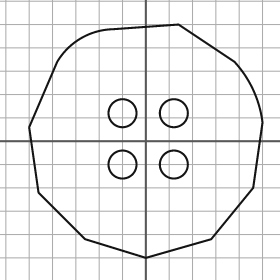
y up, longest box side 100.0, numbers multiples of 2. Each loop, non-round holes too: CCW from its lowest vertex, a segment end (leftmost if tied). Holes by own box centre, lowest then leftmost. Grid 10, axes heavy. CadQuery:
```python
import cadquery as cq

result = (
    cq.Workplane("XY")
    .moveTo(0.0, -50.0)
    .lineTo(28.0, -42.0)
    .lineTo(46.0, -20.0)
    .lineTo(50.0, 8.0)
    .threePointArc((46.0, 22.0), (38.0, 34.0))
    .lineTo(14.0, 50.0)
    .lineTo(-14.0, 48.0)
    .threePointArc((-28.0, 44.0), (-38.0, 34.0))
    .lineTo(-50.0, 6.0)
    .lineTo(-46.0, -22.0)
    .lineTo(-26.0, -42.0)
    .close()
    .moveTo(-10.0, -10.0)
    .circle(6.0)
    .moveTo(12.0, -10.0)
    .circle(6.0)
    .moveTo(-10.0, 12.0)
    .circle(6.0)
    .moveTo(12.0, 12.0)
    .circle(6.0)
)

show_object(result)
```